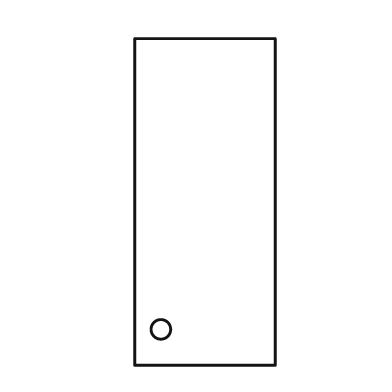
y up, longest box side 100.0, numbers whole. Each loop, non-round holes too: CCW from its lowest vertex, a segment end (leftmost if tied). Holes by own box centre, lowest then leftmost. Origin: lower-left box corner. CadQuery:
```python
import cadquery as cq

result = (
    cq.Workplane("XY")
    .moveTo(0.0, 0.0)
    .lineTo(43.0, 0.0)
    .lineTo(43.0, 100.0)
    .lineTo(0.0, 100.0)
    .close()
    .moveTo(8.0, 11.0)
    .circle(3.0)
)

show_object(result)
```